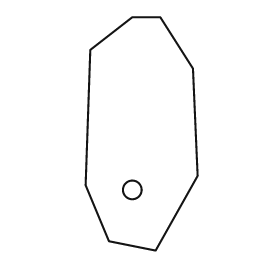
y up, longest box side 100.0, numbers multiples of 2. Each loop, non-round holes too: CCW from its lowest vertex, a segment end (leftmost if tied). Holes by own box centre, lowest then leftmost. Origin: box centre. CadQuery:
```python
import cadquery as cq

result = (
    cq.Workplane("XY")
    .moveTo(6.0, -50.0)
    .lineTo(24.0, -18.0)
    .lineTo(22.0, 28.0)
    .lineTo(8.0, 50.0)
    .lineTo(-4.0, 50.0)
    .lineTo(-22.0, 36.0)
    .lineTo(-24.0, -22.0)
    .lineTo(-14.0, -46.0)
    .close()
    .moveTo(-4.0, -24.0)
    .circle(4.0)
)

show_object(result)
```